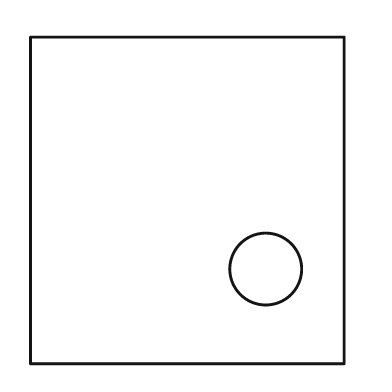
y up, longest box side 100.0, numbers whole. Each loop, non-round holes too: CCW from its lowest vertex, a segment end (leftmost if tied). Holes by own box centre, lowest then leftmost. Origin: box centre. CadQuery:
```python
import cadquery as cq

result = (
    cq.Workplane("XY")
    .moveTo(-48.0, -50.0)
    .lineTo(48.0, -50.0)
    .lineTo(48.0, 50.0)
    .lineTo(-48.0, 50.0)
    .close()
    .moveTo(24.0, -21.0)
    .circle(11.0)
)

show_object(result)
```